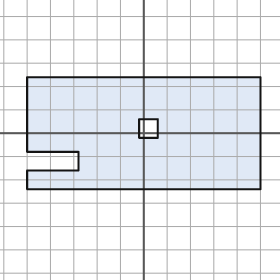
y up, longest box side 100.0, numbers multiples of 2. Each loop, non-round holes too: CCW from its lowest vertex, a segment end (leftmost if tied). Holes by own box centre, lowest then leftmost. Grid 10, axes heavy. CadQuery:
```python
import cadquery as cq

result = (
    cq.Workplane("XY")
    .moveTo(-50.0, -24.0)
    .lineTo(50.0, -24.0)
    .lineTo(50.0, 24.0)
    .lineTo(-50.0, 24.0)
    .lineTo(-50.0, -8.0)
    .lineTo(-28.0, -8.0)
    .lineTo(-28.0, -16.0)
    .lineTo(-50.0, -16.0)
    .close()
    .moveTo(-2.0, -2.0)
    .lineTo(6.0, -2.0)
    .lineTo(6.0, 6.0)
    .lineTo(-2.0, 6.0)
    .close()
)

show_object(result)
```